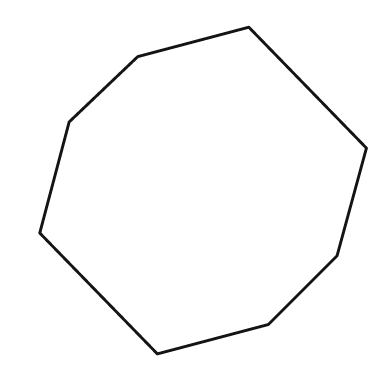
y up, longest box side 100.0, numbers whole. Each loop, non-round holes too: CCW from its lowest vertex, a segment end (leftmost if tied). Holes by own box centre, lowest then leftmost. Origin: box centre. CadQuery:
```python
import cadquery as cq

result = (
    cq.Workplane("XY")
    .moveTo(-14.0, -50.0)
    .lineTo(20.0, -41.0)
    .lineTo(41.0, -20.0)
    .lineTo(50.0, 13.0)
    .lineTo(14.0, 50.0)
    .lineTo(-20.0, 41.0)
    .lineTo(-41.0, 21.0)
    .lineTo(-50.0, -13.0)
    .close()
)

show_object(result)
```